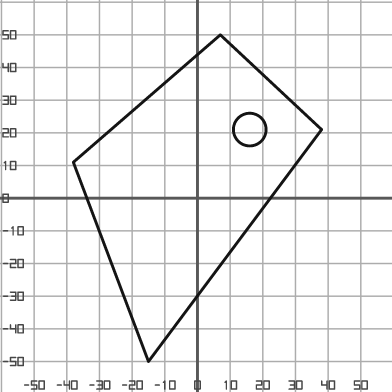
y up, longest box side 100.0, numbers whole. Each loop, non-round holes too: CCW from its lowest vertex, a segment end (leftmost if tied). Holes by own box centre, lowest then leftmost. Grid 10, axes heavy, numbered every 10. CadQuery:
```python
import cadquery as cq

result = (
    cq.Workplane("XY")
    .moveTo(-15.0, -50.0)
    .lineTo(38.0, 21.0)
    .lineTo(7.0, 50.0)
    .lineTo(-38.0, 11.0)
    .close()
    .moveTo(16.0, 21.0)
    .circle(5.0)
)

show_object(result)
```